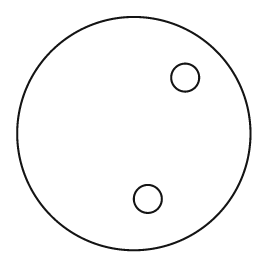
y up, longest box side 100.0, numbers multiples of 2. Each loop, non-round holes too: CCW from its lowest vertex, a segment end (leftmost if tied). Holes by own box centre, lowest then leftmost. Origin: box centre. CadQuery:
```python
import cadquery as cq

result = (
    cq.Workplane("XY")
    .moveTo(0.0, 0.0)
    .circle(50.0)
    .moveTo(6.0, -28.0)
    .circle(6.0)
    .moveTo(22.0, 24.0)
    .circle(6.0)
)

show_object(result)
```